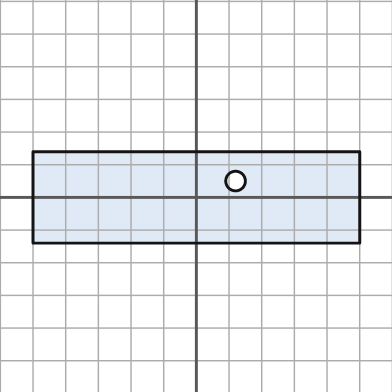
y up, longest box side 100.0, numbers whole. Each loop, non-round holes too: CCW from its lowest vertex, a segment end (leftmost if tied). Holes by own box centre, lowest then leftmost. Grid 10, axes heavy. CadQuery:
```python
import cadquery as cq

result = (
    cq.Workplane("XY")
    .moveTo(-50.0, -14.0)
    .lineTo(50.0, -14.0)
    .lineTo(50.0, 14.0)
    .lineTo(-50.0, 14.0)
    .close()
    .moveTo(12.0, 5.0)
    .circle(3.0)
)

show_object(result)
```